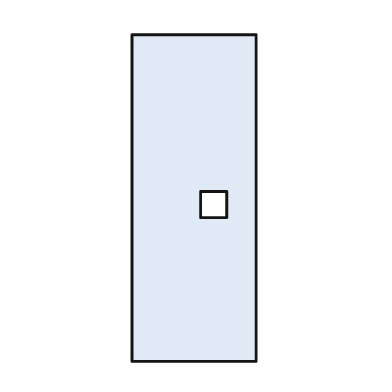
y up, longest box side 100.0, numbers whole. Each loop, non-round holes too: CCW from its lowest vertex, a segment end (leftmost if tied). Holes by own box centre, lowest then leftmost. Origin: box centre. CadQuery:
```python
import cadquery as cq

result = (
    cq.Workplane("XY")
    .moveTo(-19.0, -50.0)
    .lineTo(19.0, -50.0)
    .lineTo(19.0, 50.0)
    .lineTo(-19.0, 50.0)
    .close()
    .moveTo(2.0, -6.0)
    .lineTo(10.0, -6.0)
    .lineTo(10.0, 2.0)
    .lineTo(2.0, 2.0)
    .close()
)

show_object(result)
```